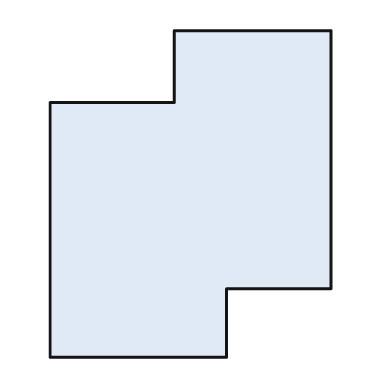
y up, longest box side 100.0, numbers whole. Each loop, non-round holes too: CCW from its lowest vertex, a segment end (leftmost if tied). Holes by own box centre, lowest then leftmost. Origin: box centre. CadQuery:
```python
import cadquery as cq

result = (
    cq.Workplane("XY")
    .moveTo(-43.0, -50.0)
    .lineTo(11.0, -50.0)
    .lineTo(11.0, -29.0)
    .lineTo(43.0, -29.0)
    .lineTo(43.0, 50.0)
    .lineTo(-5.0, 50.0)
    .lineTo(-5.0, 28.0)
    .lineTo(-43.0, 28.0)
    .close()
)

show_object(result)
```